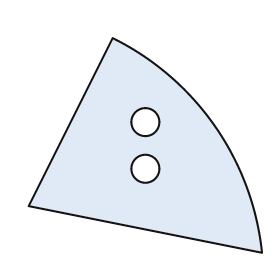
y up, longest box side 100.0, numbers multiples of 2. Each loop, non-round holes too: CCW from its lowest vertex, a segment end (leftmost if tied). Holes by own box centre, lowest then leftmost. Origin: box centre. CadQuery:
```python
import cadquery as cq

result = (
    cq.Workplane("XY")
    .moveTo(50.0, -46.0)
    .threePointArc((30.0, 8.0), (-14.0, 46.0))
    .lineTo(-50.0, -26.0)
    .close()
    .moveTo(0.0, -10.0)
    .circle(6.0)
    .moveTo(0.0, 10.0)
    .circle(6.0)
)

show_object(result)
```